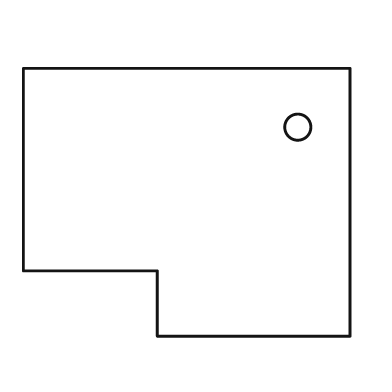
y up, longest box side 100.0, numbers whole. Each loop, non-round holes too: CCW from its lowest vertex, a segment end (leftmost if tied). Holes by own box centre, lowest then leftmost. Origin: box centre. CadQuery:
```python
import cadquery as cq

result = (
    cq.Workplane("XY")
    .moveTo(-9.0, -41.0)
    .lineTo(50.0, -41.0)
    .lineTo(50.0, 41.0)
    .lineTo(-50.0, 41.0)
    .lineTo(-50.0, -21.0)
    .lineTo(-9.0, -21.0)
    .close()
    .moveTo(34.0, 23.0)
    .circle(4.0)
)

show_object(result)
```